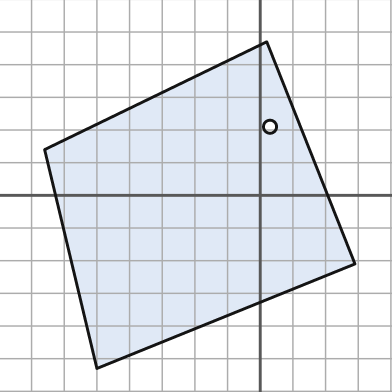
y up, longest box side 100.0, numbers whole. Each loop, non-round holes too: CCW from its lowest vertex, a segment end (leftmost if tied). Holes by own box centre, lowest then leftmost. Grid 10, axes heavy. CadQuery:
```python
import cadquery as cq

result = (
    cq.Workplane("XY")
    .moveTo(-50.0, -53.0)
    .lineTo(29.0, -21.0)
    .lineTo(2.0, 47.0)
    .lineTo(-66.0, 14.0)
    .close()
    .moveTo(3.0, 21.0)
    .circle(2.0)
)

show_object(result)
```